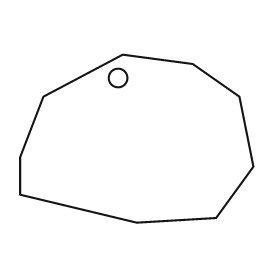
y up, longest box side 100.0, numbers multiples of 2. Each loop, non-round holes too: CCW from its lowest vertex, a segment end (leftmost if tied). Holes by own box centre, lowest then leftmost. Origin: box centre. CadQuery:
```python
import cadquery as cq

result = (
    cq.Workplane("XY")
    .moveTo(0.0, -36.0)
    .lineTo(34.0, -34.0)
    .lineTo(50.0, -12.0)
    .lineTo(44.0, 18.0)
    .lineTo(24.0, 32.0)
    .lineTo(-6.0, 36.0)
    .lineTo(-40.0, 18.0)
    .lineTo(-50.0, -8.0)
    .lineTo(-50.0, -24.0)
    .close()
    .moveTo(-8.0, 26.0)
    .circle(4.0)
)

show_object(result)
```